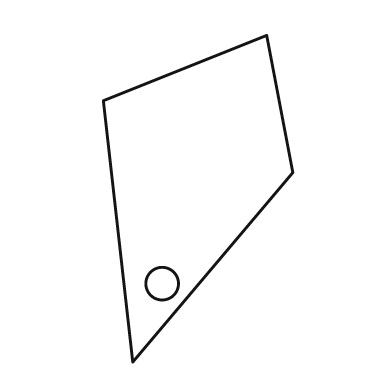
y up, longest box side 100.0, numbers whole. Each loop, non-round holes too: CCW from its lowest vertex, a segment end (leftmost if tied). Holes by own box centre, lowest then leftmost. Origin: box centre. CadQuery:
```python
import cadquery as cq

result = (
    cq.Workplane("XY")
    .moveTo(-20.0, -50.0)
    .lineTo(29.0, 8.0)
    .lineTo(21.0, 50.0)
    .lineTo(-29.0, 30.0)
    .close()
    .moveTo(-11.0, -26.0)
    .circle(5.0)
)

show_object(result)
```